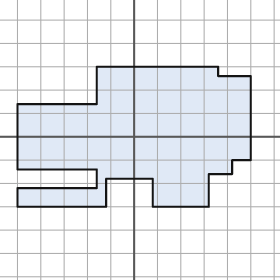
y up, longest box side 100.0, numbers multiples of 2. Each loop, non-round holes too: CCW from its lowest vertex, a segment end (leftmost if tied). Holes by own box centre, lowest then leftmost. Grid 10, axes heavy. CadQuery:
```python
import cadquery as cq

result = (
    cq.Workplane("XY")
    .moveTo(-50.0, -30.0)
    .lineTo(-12.0, -30.0)
    .lineTo(-12.0, -18.0)
    .lineTo(8.0, -18.0)
    .lineTo(8.0, -30.0)
    .lineTo(32.0, -30.0)
    .lineTo(32.0, -16.0)
    .lineTo(42.0, -16.0)
    .lineTo(42.0, -10.0)
    .lineTo(50.0, -10.0)
    .lineTo(50.0, 26.0)
    .lineTo(36.0, 26.0)
    .lineTo(36.0, 30.0)
    .lineTo(-16.0, 30.0)
    .lineTo(-16.0, 14.0)
    .lineTo(-50.0, 14.0)
    .lineTo(-50.0, -14.0)
    .lineTo(-16.0, -14.0)
    .lineTo(-16.0, -22.0)
    .lineTo(-50.0, -22.0)
    .close()
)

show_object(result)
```